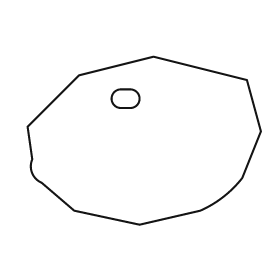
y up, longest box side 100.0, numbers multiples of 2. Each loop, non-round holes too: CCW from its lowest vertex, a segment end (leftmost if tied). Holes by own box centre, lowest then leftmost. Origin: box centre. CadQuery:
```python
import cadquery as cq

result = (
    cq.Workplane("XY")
    .moveTo(-2.0, -36.0)
    .lineTo(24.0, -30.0)
    .threePointArc((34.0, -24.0), (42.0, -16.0))
    .lineTo(50.0, 4.0)
    .lineTo(44.0, 26.0)
    .lineTo(4.0, 36.0)
    .lineTo(-28.0, 28.0)
    .lineTo(-50.0, 6.0)
    .lineTo(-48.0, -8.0)
    .threePointArc((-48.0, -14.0), (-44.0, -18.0))
    .lineTo(-30.0, -30.0)
    .close()
    .moveTo(-10.0, 14.0)
    .lineTo(-6.0, 14.0)
    .threePointArc((-2.0, 18.0), (-6.0, 22.0))
    .lineTo(-10.0, 22.0)
    .threePointArc((-14.0, 18.0), (-10.0, 14.0))
    .close()
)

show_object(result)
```